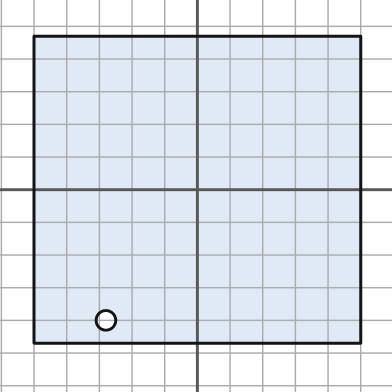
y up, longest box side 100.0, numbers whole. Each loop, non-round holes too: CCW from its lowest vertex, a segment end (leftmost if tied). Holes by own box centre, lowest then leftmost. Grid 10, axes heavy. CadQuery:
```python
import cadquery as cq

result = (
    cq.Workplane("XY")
    .moveTo(-50.0, -47.0)
    .lineTo(50.0, -47.0)
    .lineTo(50.0, 47.0)
    .lineTo(-50.0, 47.0)
    .close()
    .moveTo(-28.0, -40.0)
    .circle(3.0)
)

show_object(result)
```